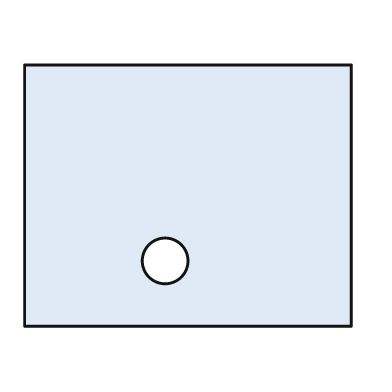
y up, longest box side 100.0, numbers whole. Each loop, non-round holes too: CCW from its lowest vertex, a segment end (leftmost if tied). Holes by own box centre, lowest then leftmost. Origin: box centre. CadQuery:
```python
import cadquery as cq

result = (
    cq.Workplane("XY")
    .moveTo(-50.0, -40.0)
    .lineTo(50.0, -40.0)
    .lineTo(50.0, 40.0)
    .lineTo(-50.0, 40.0)
    .close()
    .moveTo(-7.0, -20.0)
    .circle(7.0)
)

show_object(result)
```